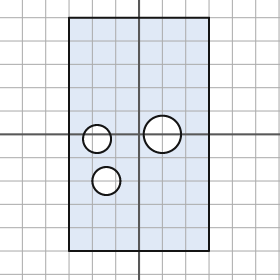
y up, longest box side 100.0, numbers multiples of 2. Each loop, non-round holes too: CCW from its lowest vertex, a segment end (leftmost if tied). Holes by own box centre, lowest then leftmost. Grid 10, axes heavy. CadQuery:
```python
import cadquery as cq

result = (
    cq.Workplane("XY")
    .moveTo(-30.0, -50.0)
    .lineTo(30.0, -50.0)
    .lineTo(30.0, 50.0)
    .lineTo(-30.0, 50.0)
    .close()
    .moveTo(-14.0, -20.0)
    .circle(6.0)
    .moveTo(-18.0, -2.0)
    .circle(6.0)
    .moveTo(10.0, 0.0)
    .circle(8.0)
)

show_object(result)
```